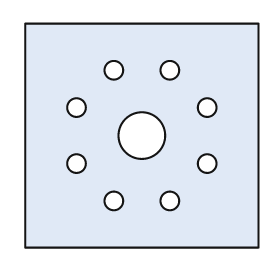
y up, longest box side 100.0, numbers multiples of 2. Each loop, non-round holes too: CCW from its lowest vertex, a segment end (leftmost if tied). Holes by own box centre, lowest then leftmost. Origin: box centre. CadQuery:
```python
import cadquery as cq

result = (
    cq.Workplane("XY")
    .moveTo(-50.0, -48.0)
    .lineTo(50.0, -48.0)
    .lineTo(50.0, 48.0)
    .lineTo(-50.0, 48.0)
    .close()
    .moveTo(-12.0, -28.0)
    .circle(4.0)
    .moveTo(12.0, -28.0)
    .circle(4.0)
    .moveTo(-28.0, -12.0)
    .circle(4.0)
    .moveTo(28.0, -12.0)
    .circle(4.0)
    .moveTo(0.0, 0.0)
    .circle(10.0)
    .moveTo(-28.0, 12.0)
    .circle(4.0)
    .moveTo(28.0, 12.0)
    .circle(4.0)
    .moveTo(-12.0, 28.0)
    .circle(4.0)
    .moveTo(12.0, 28.0)
    .circle(4.0)
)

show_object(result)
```